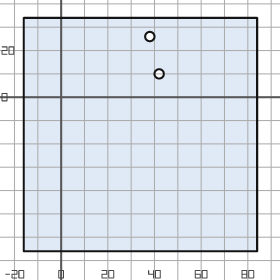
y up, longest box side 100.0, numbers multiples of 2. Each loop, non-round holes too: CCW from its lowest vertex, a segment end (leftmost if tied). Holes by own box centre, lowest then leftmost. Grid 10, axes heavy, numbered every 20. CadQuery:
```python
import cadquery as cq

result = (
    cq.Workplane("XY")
    .moveTo(-16.0, -66.0)
    .lineTo(84.0, -66.0)
    .lineTo(84.0, 34.0)
    .lineTo(-16.0, 34.0)
    .close()
    .moveTo(42.0, 10.0)
    .circle(2.0)
    .moveTo(38.0, 26.0)
    .circle(2.0)
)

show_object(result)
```